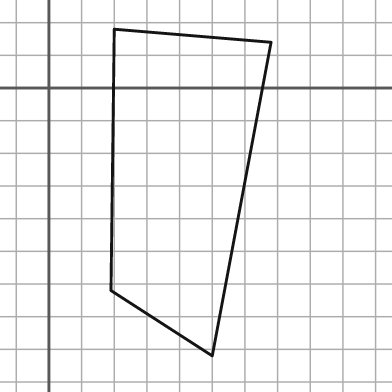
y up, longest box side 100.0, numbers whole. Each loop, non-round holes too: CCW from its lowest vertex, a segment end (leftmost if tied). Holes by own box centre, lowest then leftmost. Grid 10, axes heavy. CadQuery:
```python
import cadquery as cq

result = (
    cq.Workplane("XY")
    .moveTo(50.0, -82.0)
    .lineTo(68.0, 14.0)
    .lineTo(20.0, 18.0)
    .lineTo(19.0, -62.0)
    .close()
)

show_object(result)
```